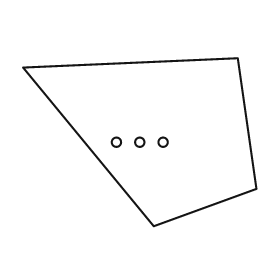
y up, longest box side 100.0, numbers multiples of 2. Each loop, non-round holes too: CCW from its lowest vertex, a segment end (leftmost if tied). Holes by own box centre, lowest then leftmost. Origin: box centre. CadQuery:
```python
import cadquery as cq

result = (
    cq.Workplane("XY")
    .moveTo(6.0, -36.0)
    .lineTo(50.0, -20.0)
    .lineTo(42.0, 36.0)
    .lineTo(-50.0, 32.0)
    .close()
    .moveTo(-10.0, 0.0)
    .circle(2.0)
    .moveTo(0.0, 0.0)
    .circle(2.0)
    .moveTo(10.0, 0.0)
    .circle(2.0)
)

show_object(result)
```